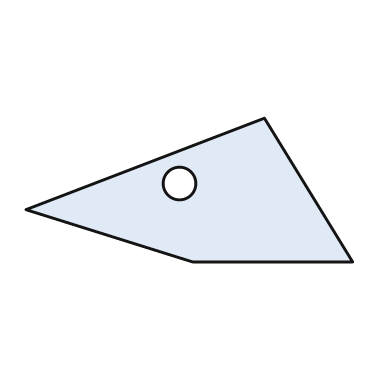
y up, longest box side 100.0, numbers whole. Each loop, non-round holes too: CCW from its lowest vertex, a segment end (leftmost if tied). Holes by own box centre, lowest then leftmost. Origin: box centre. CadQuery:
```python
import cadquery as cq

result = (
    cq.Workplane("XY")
    .moveTo(1.0, -22.0)
    .lineTo(50.0, -22.0)
    .lineTo(23.0, 22.0)
    .lineTo(-50.0, -6.0)
    .close()
    .moveTo(-3.0, 2.0)
    .circle(5.0)
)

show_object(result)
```